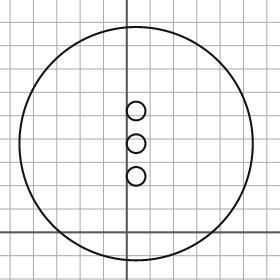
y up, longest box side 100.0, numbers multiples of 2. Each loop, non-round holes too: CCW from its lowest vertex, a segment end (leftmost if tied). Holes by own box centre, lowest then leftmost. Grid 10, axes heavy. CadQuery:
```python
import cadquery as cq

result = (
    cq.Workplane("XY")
    .moveTo(4.0, 38.0)
    .circle(50.0)
    .moveTo(4.0, 24.0)
    .circle(4.0)
    .moveTo(4.0, 38.0)
    .circle(4.0)
    .moveTo(4.0, 52.0)
    .circle(4.0)
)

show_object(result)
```